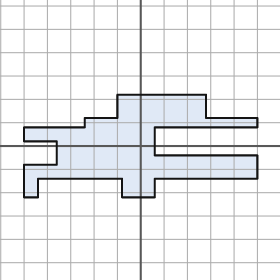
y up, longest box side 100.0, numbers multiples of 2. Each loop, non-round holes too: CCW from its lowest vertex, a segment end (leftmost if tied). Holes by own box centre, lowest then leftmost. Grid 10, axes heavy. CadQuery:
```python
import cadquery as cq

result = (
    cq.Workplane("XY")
    .moveTo(-50.0, -22.0)
    .lineTo(-44.0, -22.0)
    .lineTo(-44.0, -14.0)
    .lineTo(-8.0, -14.0)
    .lineTo(-8.0, -22.0)
    .lineTo(6.0, -22.0)
    .lineTo(6.0, -14.0)
    .lineTo(50.0, -14.0)
    .lineTo(50.0, -4.0)
    .lineTo(6.0, -4.0)
    .lineTo(6.0, 8.0)
    .lineTo(50.0, 8.0)
    .lineTo(50.0, 12.0)
    .lineTo(28.0, 12.0)
    .lineTo(28.0, 22.0)
    .lineTo(-10.0, 22.0)
    .lineTo(-10.0, 12.0)
    .lineTo(-24.0, 12.0)
    .lineTo(-24.0, 8.0)
    .lineTo(-50.0, 8.0)
    .lineTo(-50.0, 2.0)
    .lineTo(-36.0, 2.0)
    .lineTo(-36.0, -8.0)
    .lineTo(-50.0, -8.0)
    .close()
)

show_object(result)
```